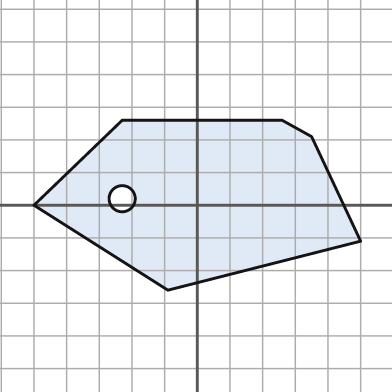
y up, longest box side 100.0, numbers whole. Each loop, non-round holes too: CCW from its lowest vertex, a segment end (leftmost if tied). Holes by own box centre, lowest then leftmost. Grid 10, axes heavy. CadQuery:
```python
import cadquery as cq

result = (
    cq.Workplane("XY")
    .moveTo(-9.0, -26.0)
    .lineTo(50.0, -11.0)
    .lineTo(35.0, 21.0)
    .lineTo(26.0, 26.0)
    .lineTo(-23.0, 26.0)
    .lineTo(-50.0, 0.0)
    .close()
    .moveTo(-23.0, 2.0)
    .circle(4.0)
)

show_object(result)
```